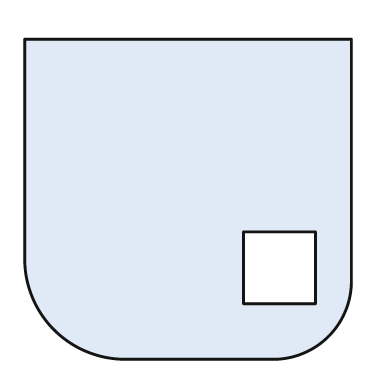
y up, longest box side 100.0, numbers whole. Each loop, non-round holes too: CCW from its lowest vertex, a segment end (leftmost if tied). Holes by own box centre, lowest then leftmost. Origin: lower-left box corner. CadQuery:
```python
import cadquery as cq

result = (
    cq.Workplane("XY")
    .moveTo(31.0, 0.0)
    .lineTo(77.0, 0.0)
    .threePointArc((93.0, 7.0), (100.0, 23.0))
    .lineTo(100.0, 98.0)
    .lineTo(0.0, 98.0)
    .lineTo(0.0, 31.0)
    .threePointArc((9.0, 9.0), (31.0, 0.0))
    .close()
    .moveTo(67.0, 17.0)
    .lineTo(89.0, 17.0)
    .lineTo(89.0, 39.0)
    .lineTo(67.0, 39.0)
    .close()
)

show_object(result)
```